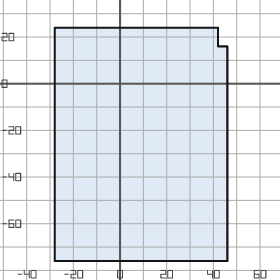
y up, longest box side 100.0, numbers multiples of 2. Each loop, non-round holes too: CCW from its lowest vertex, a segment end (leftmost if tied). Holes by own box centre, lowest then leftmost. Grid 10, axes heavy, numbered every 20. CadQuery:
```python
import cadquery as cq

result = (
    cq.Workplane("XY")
    .moveTo(-28.0, -76.0)
    .lineTo(46.0, -76.0)
    .lineTo(46.0, 16.0)
    .lineTo(42.0, 16.0)
    .lineTo(42.0, 24.0)
    .lineTo(-28.0, 24.0)
    .close()
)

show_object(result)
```